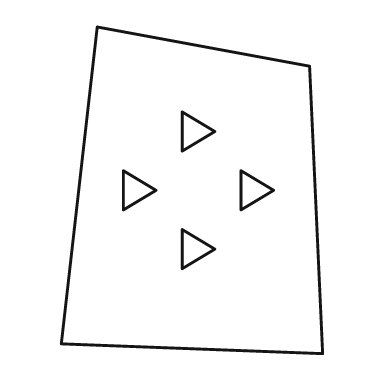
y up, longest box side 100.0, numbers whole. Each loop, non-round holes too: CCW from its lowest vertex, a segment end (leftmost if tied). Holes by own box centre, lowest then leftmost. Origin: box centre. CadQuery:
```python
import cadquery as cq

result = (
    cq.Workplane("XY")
    .moveTo(40.0, -50.0)
    .lineTo(36.0, 38.0)
    .lineTo(-29.0, 50.0)
    .lineTo(-40.0, -47.0)
    .close()
    .moveTo(-3.0, -24.0)
    .lineTo(7.0, -18.0)
    .lineTo(-3.0, -12.0)
    .close()
    .moveTo(-21.0, -6.0)
    .lineTo(-11.0, 0.0)
    .lineTo(-21.0, 6.0)
    .close()
    .moveTo(15.0, -6.0)
    .lineTo(25.0, 0.0)
    .lineTo(15.0, 6.0)
    .close()
    .moveTo(-3.0, 12.0)
    .lineTo(7.0, 18.0)
    .lineTo(-3.0, 24.0)
    .close()
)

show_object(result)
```